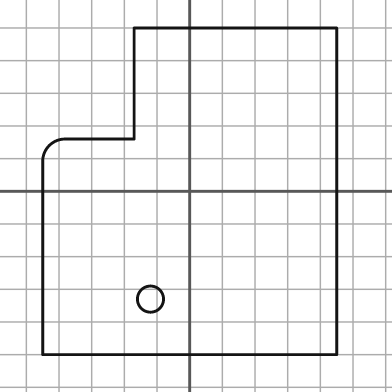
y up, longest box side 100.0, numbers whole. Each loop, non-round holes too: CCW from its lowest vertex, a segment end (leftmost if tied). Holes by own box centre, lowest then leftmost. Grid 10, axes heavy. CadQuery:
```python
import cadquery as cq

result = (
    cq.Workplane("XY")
    .moveTo(-45.0, -50.0)
    .lineTo(45.0, -50.0)
    .lineTo(45.0, 50.0)
    .lineTo(-17.0, 50.0)
    .lineTo(-17.0, 16.0)
    .lineTo(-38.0, 16.0)
    .threePointArc((-43.0, 14.0), (-45.0, 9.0))
    .close()
    .moveTo(-12.0, -33.0)
    .circle(4.0)
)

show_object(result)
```